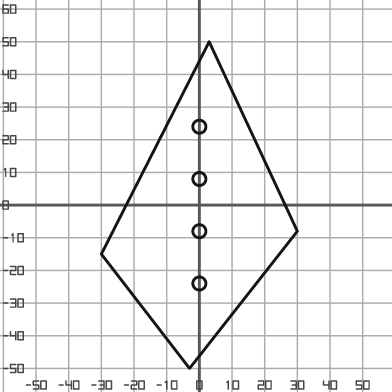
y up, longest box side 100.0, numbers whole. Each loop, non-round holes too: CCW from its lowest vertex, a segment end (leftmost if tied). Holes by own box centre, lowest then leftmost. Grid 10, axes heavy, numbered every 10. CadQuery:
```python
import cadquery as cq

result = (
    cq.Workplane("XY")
    .moveTo(-3.0, -50.0)
    .lineTo(30.0, -8.0)
    .lineTo(3.0, 50.0)
    .lineTo(-30.0, -15.0)
    .close()
    .moveTo(0.0, -24.0)
    .circle(2.0)
    .moveTo(0.0, -8.0)
    .circle(2.0)
    .moveTo(0.0, 8.0)
    .circle(2.0)
    .moveTo(0.0, 24.0)
    .circle(2.0)
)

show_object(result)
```